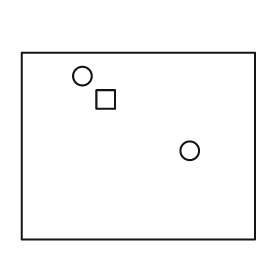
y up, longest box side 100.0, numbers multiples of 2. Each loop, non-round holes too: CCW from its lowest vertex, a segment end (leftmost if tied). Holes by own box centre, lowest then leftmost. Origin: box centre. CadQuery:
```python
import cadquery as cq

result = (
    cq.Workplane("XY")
    .moveTo(-50.0, -40.0)
    .lineTo(50.0, -40.0)
    .lineTo(50.0, 40.0)
    .lineTo(-50.0, 40.0)
    .close()
    .moveTo(22.0, -2.0)
    .circle(4.0)
    .moveTo(-18.0, 16.0)
    .lineTo(-10.0, 16.0)
    .lineTo(-10.0, 24.0)
    .lineTo(-18.0, 24.0)
    .close()
    .moveTo(-24.0, 30.0)
    .circle(4.0)
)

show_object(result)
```